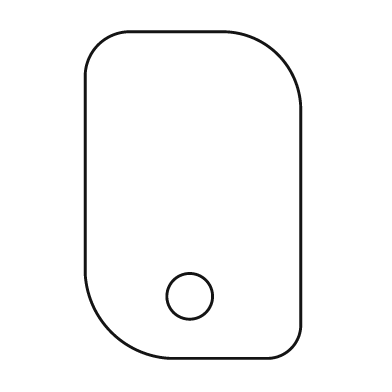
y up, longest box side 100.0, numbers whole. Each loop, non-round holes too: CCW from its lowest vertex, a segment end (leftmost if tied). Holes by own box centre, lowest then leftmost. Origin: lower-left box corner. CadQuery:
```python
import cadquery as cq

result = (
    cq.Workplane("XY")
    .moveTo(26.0, 0.0)
    .lineTo(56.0, 0.0)
    .threePointArc((63.0, 3.0), (66.0, 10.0))
    .lineTo(66.0, 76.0)
    .threePointArc((59.0, 93.0), (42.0, 100.0))
    .lineTo(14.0, 100.0)
    .threePointArc((4.0, 96.0), (0.0, 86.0))
    .lineTo(0.0, 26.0)
    .threePointArc((8.0, 8.0), (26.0, 0.0))
    .close()
    .moveTo(32.0, 19.0)
    .circle(7.0)
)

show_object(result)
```